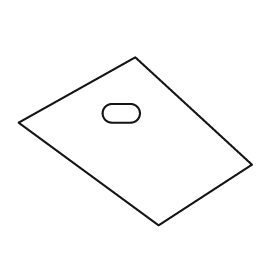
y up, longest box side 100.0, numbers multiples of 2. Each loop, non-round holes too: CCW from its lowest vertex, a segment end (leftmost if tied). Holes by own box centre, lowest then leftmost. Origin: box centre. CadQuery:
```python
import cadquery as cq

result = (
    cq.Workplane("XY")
    .moveTo(10.0, -36.0)
    .lineTo(50.0, -10.0)
    .lineTo(0.0, 36.0)
    .lineTo(-50.0, 8.0)
    .close()
    .moveTo(-10.0, 8.0)
    .lineTo(-2.0, 8.0)
    .threePointArc((2.0, 12.0), (-2.0, 16.0))
    .lineTo(-10.0, 16.0)
    .threePointArc((-14.0, 12.0), (-10.0, 8.0))
    .close()
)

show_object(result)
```